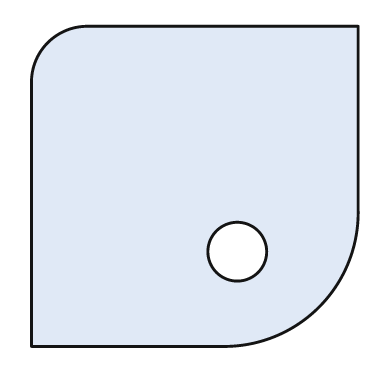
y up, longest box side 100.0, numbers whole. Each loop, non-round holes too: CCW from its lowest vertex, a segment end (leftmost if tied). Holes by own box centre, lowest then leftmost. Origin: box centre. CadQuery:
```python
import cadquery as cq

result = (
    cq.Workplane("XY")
    .moveTo(-50.0, -49.0)
    .lineTo(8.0, -49.0)
    .threePointArc((38.0, -37.0), (50.0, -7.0))
    .lineTo(50.0, 49.0)
    .lineTo(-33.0, 49.0)
    .threePointArc((-45.0, 44.0), (-50.0, 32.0))
    .close()
    .moveTo(13.0, -20.0)
    .circle(9.0)
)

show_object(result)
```